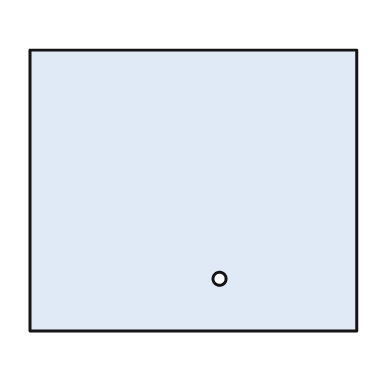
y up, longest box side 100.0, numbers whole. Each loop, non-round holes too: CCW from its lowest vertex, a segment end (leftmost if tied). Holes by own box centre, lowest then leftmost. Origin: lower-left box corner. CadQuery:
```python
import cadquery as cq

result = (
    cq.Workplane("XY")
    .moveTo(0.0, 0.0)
    .lineTo(100.0, 0.0)
    .lineTo(100.0, 86.0)
    .lineTo(0.0, 86.0)
    .close()
    .moveTo(58.0, 16.0)
    .circle(2.0)
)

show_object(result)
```